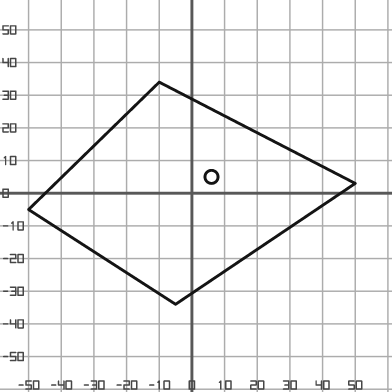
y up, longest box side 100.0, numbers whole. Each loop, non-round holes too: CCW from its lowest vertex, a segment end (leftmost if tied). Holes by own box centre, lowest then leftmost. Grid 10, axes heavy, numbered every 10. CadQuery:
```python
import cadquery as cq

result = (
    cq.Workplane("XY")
    .moveTo(-5.0, -34.0)
    .lineTo(50.0, 3.0)
    .lineTo(-10.0, 34.0)
    .lineTo(-50.0, -5.0)
    .close()
    .moveTo(6.0, 5.0)
    .circle(2.0)
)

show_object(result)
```